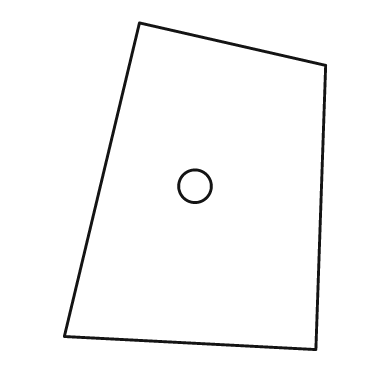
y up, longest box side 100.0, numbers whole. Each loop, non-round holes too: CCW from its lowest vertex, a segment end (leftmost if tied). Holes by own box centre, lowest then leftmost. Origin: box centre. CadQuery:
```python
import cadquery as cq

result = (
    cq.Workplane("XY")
    .moveTo(37.0, -50.0)
    .lineTo(40.0, 37.0)
    .lineTo(-17.0, 50.0)
    .lineTo(-40.0, -46.0)
    .close()
    .moveTo(0.0, 0.0)
    .circle(5.0)
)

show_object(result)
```